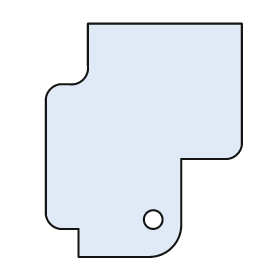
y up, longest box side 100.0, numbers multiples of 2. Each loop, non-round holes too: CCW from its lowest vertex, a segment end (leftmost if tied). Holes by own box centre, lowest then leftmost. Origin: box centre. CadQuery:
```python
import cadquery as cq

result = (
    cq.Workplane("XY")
    .moveTo(-28.0, -50.0)
    .lineTo(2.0, -50.0)
    .threePointArc((12.0, -46.0), (16.0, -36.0))
    .lineTo(16.0, -8.0)
    .lineTo(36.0, -8.0)
    .threePointArc((40.0, -6.0), (42.0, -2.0))
    .lineTo(42.0, 50.0)
    .lineTo(-24.0, 50.0)
    .lineTo(-24.0, 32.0)
    .threePointArc((-26.0, 26.0), (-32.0, 24.0))
    .lineTo(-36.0, 24.0)
    .threePointArc((-40.0, 22.0), (-42.0, 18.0))
    .lineTo(-42.0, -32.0)
    .threePointArc((-40.0, -36.0), (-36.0, -38.0))
    .lineTo(-28.0, -38.0)
    .close()
    .moveTo(4.0, -34.0)
    .circle(4.0)
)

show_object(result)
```